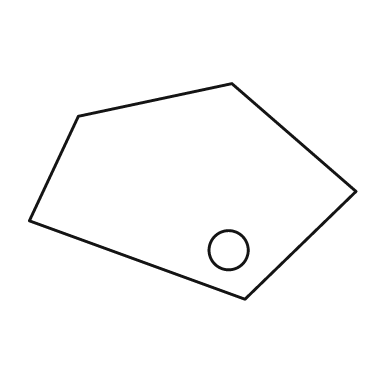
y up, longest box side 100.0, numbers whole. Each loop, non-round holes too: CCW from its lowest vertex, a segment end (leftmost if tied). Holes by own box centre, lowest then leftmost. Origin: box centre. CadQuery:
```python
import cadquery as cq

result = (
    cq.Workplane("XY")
    .moveTo(16.0, -33.0)
    .lineTo(50.0, 0.0)
    .lineTo(12.0, 33.0)
    .lineTo(-35.0, 23.0)
    .lineTo(-50.0, -9.0)
    .close()
    .moveTo(11.0, -18.0)
    .circle(6.0)
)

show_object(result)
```